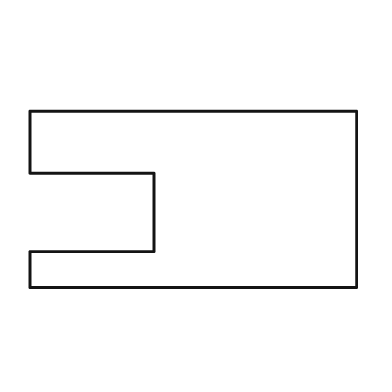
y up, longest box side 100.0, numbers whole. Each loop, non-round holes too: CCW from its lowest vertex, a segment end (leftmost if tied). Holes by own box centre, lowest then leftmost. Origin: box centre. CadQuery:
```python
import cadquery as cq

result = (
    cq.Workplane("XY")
    .moveTo(-50.0, -27.0)
    .lineTo(50.0, -27.0)
    .lineTo(50.0, 27.0)
    .lineTo(-50.0, 27.0)
    .lineTo(-50.0, 8.0)
    .lineTo(-12.0, 8.0)
    .lineTo(-12.0, -16.0)
    .lineTo(-50.0, -16.0)
    .close()
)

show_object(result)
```